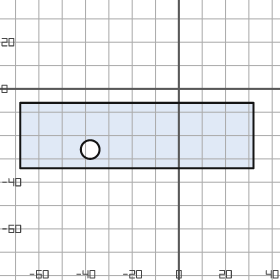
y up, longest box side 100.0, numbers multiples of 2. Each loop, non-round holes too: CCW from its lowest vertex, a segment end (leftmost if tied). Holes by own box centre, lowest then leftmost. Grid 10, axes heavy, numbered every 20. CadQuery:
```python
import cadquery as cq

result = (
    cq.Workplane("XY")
    .moveTo(-68.0, -34.0)
    .lineTo(32.0, -34.0)
    .lineTo(32.0, -6.0)
    .lineTo(-68.0, -6.0)
    .close()
    .moveTo(-38.0, -26.0)
    .circle(4.0)
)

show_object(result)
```